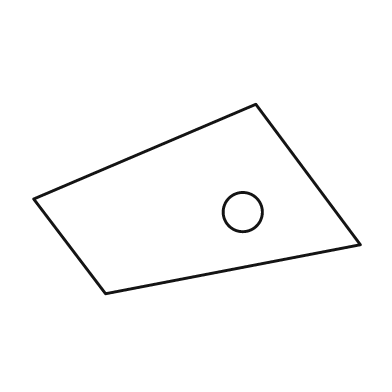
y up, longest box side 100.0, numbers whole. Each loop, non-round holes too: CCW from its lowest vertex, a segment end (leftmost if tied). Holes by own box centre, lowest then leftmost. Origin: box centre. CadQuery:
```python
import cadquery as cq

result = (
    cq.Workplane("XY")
    .moveTo(-28.0, -29.0)
    .lineTo(50.0, -14.0)
    .lineTo(18.0, 29.0)
    .lineTo(-50.0, 0.0)
    .close()
    .moveTo(14.0, -4.0)
    .circle(6.0)
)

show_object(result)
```